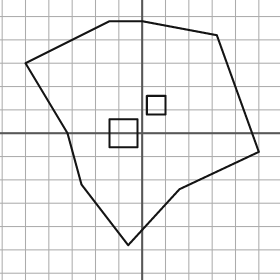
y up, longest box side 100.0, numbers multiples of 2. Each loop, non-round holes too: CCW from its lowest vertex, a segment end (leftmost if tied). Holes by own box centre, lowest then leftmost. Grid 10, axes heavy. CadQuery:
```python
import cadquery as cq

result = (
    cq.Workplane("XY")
    .moveTo(-6.0, -48.0)
    .lineTo(16.0, -24.0)
    .lineTo(50.0, -8.0)
    .lineTo(32.0, 42.0)
    .lineTo(0.0, 48.0)
    .lineTo(-14.0, 48.0)
    .lineTo(-50.0, 30.0)
    .lineTo(-32.0, 0.0)
    .lineTo(-26.0, -22.0)
    .close()
    .moveTo(-14.0, -6.0)
    .lineTo(-2.0, -6.0)
    .lineTo(-2.0, 6.0)
    .lineTo(-14.0, 6.0)
    .close()
    .moveTo(2.0, 8.0)
    .lineTo(10.0, 8.0)
    .lineTo(10.0, 16.0)
    .lineTo(2.0, 16.0)
    .close()
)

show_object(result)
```